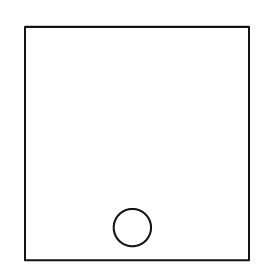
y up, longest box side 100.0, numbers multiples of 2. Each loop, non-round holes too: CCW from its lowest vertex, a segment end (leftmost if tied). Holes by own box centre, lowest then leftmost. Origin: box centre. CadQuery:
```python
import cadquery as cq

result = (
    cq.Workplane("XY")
    .moveTo(-48.0, -50.0)
    .lineTo(48.0, -50.0)
    .lineTo(48.0, 50.0)
    .lineTo(-48.0, 50.0)
    .close()
    .moveTo(-2.0, -36.0)
    .circle(8.0)
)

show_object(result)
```